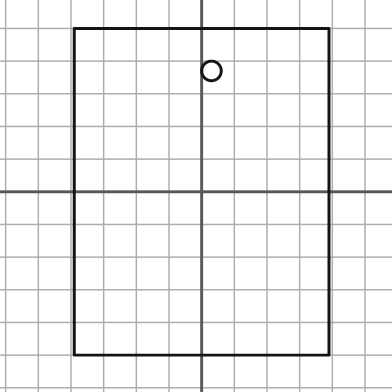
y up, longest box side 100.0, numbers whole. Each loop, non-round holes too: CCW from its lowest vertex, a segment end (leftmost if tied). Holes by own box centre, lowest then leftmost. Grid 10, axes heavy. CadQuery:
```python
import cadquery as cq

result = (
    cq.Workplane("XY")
    .moveTo(-39.0, -50.0)
    .lineTo(39.0, -50.0)
    .lineTo(39.0, 50.0)
    .lineTo(-39.0, 50.0)
    .close()
    .moveTo(3.0, 37.0)
    .circle(3.0)
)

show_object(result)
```